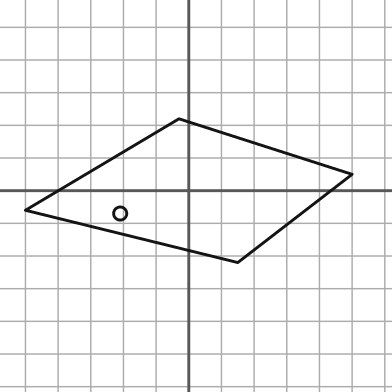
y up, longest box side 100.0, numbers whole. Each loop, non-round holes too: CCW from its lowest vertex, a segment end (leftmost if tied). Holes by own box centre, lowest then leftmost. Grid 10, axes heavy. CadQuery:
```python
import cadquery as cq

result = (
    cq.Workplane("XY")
    .moveTo(15.0, -22.0)
    .lineTo(50.0, 5.0)
    .lineTo(-3.0, 22.0)
    .lineTo(-50.0, -6.0)
    .close()
    .moveTo(-21.0, -7.0)
    .circle(2.0)
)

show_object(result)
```